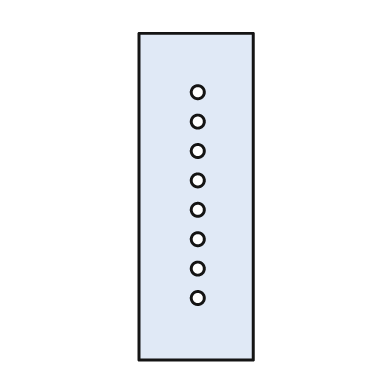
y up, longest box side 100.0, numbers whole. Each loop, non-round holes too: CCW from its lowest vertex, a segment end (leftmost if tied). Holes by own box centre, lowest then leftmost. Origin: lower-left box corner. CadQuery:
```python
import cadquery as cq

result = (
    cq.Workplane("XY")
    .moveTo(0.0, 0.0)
    .lineTo(35.0, 0.0)
    .lineTo(35.0, 100.0)
    .lineTo(0.0, 100.0)
    .close()
    .moveTo(18.0, 19.0)
    .circle(2.0)
    .moveTo(18.0, 28.0)
    .circle(2.0)
    .moveTo(18.0, 37.0)
    .circle(2.0)
    .moveTo(18.0, 46.0)
    .circle(2.0)
    .moveTo(18.0, 55.0)
    .circle(2.0)
    .moveTo(18.0, 64.0)
    .circle(2.0)
    .moveTo(18.0, 73.0)
    .circle(2.0)
    .moveTo(18.0, 82.0)
    .circle(2.0)
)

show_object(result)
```